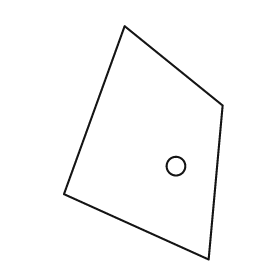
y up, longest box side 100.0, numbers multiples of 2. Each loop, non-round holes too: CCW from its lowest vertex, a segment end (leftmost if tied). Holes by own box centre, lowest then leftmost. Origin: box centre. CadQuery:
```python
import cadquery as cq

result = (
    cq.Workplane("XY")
    .moveTo(28.0, -50.0)
    .lineTo(34.0, 16.0)
    .lineTo(-8.0, 50.0)
    .lineTo(-34.0, -22.0)
    .close()
    .moveTo(14.0, -10.0)
    .circle(4.0)
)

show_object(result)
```